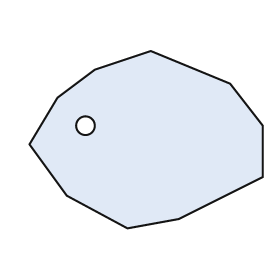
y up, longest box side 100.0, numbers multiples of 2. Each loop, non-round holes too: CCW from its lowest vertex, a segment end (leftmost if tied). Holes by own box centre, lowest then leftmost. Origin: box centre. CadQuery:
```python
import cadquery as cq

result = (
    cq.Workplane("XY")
    .moveTo(-8.0, -38.0)
    .lineTo(14.0, -34.0)
    .lineTo(50.0, -16.0)
    .lineTo(50.0, 6.0)
    .lineTo(36.0, 24.0)
    .lineTo(2.0, 38.0)
    .lineTo(-22.0, 30.0)
    .lineTo(-38.0, 18.0)
    .lineTo(-50.0, -2.0)
    .lineTo(-34.0, -24.0)
    .close()
    .moveTo(-26.0, 6.0)
    .circle(4.0)
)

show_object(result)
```